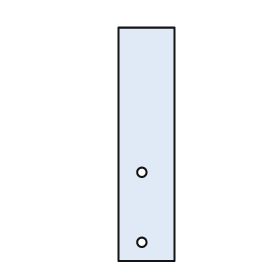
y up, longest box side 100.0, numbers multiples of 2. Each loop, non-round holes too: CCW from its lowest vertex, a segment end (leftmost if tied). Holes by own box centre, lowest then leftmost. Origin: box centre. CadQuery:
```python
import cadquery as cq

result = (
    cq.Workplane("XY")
    .moveTo(-12.0, -50.0)
    .lineTo(12.0, -50.0)
    .lineTo(12.0, 50.0)
    .lineTo(-12.0, 50.0)
    .close()
    .moveTo(-2.0, -42.0)
    .circle(2.0)
    .moveTo(-2.0, -12.0)
    .circle(2.0)
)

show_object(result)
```